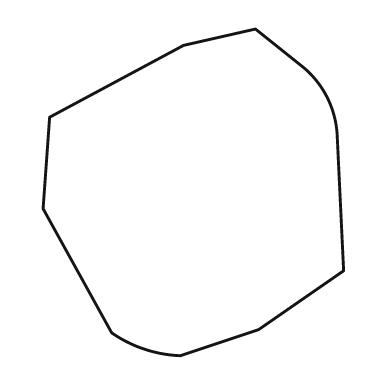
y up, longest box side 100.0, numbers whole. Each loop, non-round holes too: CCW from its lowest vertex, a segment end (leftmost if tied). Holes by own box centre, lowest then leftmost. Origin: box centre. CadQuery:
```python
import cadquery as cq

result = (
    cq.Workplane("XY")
    .moveTo(-4.0, -50.0)
    .lineTo(20.0, -42.0)
    .lineTo(46.0, -24.0)
    .lineTo(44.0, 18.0)
    .threePointArc((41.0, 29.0), (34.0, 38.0))
    .lineTo(19.0, 50.0)
    .lineTo(-3.0, 45.0)
    .lineTo(-44.0, 23.0)
    .lineTo(-46.0, -5.0)
    .lineTo(-25.0, -43.0)
    .threePointArc((-15.0, -48.0), (-4.0, -50.0))
    .close()
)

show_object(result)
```